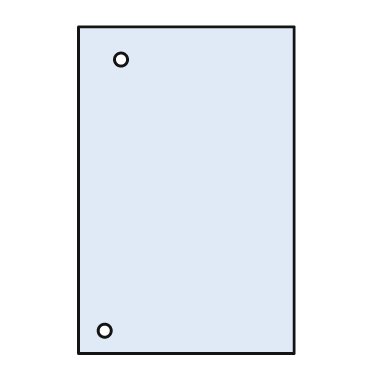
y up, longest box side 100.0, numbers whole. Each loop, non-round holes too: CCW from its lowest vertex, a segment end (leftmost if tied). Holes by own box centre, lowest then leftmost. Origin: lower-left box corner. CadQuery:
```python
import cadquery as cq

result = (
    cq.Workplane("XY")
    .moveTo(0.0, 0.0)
    .lineTo(66.0, 0.0)
    .lineTo(66.0, 100.0)
    .lineTo(0.0, 100.0)
    .close()
    .moveTo(8.0, 7.0)
    .circle(2.0)
    .moveTo(13.0, 90.0)
    .circle(2.0)
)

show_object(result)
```